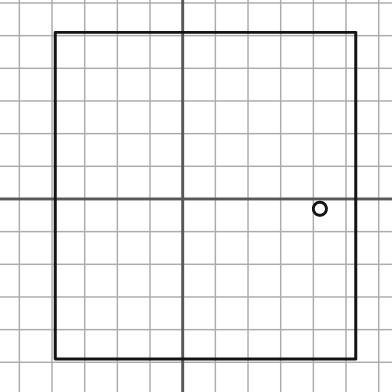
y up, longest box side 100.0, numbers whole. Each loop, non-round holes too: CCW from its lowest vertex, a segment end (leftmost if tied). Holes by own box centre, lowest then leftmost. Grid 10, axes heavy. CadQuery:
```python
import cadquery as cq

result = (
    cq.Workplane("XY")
    .moveTo(-39.0, -49.0)
    .lineTo(53.0, -49.0)
    .lineTo(53.0, 51.0)
    .lineTo(-39.0, 51.0)
    .close()
    .moveTo(42.0, -3.0)
    .circle(2.0)
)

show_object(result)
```